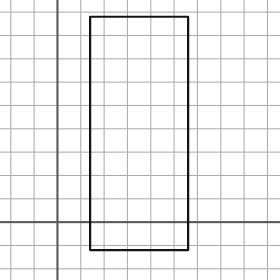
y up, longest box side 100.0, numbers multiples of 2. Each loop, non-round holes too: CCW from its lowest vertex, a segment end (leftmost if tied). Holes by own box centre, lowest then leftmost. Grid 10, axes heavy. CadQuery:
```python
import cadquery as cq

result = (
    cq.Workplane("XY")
    .moveTo(14.0, -12.0)
    .lineTo(56.0, -12.0)
    .lineTo(56.0, 88.0)
    .lineTo(14.0, 88.0)
    .close()
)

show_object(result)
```